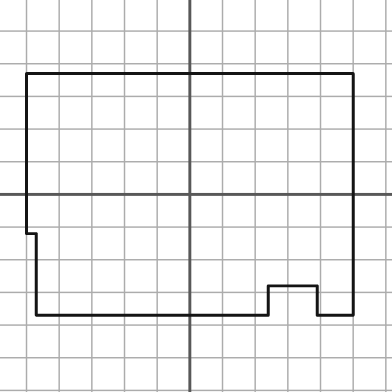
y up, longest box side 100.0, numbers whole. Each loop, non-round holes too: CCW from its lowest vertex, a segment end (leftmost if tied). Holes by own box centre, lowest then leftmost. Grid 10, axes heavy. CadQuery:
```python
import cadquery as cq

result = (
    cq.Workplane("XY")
    .moveTo(-47.0, -37.0)
    .lineTo(24.0, -37.0)
    .lineTo(24.0, -28.0)
    .lineTo(39.0, -28.0)
    .lineTo(39.0, -37.0)
    .lineTo(50.0, -37.0)
    .lineTo(50.0, 37.0)
    .lineTo(-50.0, 37.0)
    .lineTo(-50.0, -12.0)
    .lineTo(-47.0, -12.0)
    .close()
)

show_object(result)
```